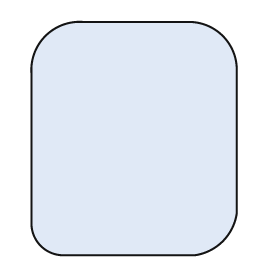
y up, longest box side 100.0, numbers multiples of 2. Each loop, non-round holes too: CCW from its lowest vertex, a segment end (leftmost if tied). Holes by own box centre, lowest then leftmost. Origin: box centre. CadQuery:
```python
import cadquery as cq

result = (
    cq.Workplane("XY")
    .moveTo(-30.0, -50.0)
    .lineTo(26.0, -50.0)
    .threePointArc((38.0, -44.0), (44.0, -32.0))
    .lineTo(44.0, 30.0)
    .threePointArc((38.0, 44.0), (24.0, 50.0))
    .lineTo(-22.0, 50.0)
    .threePointArc((-38.0, 44.0), (-44.0, 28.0))
    .lineTo(-44.0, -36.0)
    .threePointArc((-40.0, -46.0), (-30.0, -50.0))
    .close()
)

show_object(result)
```